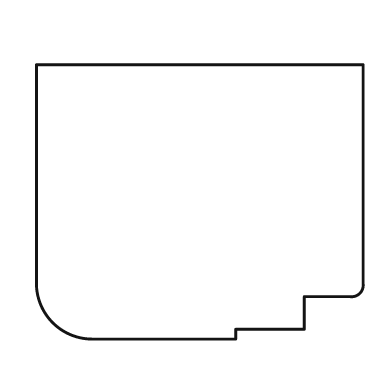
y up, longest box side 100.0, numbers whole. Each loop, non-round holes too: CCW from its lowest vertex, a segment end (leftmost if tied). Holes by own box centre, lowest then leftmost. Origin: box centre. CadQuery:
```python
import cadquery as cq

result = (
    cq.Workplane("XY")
    .moveTo(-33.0, -42.0)
    .lineTo(11.0, -42.0)
    .lineTo(11.0, -39.0)
    .lineTo(32.0, -39.0)
    .lineTo(32.0, -29.0)
    .lineTo(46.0, -29.0)
    .threePointArc((49.0, -28.0), (50.0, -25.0))
    .lineTo(50.0, 42.0)
    .lineTo(-50.0, 42.0)
    .lineTo(-50.0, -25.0)
    .threePointArc((-45.0, -37.0), (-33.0, -42.0))
    .close()
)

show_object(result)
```